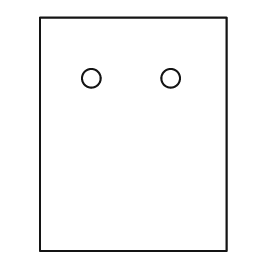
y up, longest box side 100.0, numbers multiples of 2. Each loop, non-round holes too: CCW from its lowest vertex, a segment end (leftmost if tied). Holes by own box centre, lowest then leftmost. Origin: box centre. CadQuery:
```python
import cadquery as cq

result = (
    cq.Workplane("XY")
    .moveTo(-40.0, -50.0)
    .lineTo(40.0, -50.0)
    .lineTo(40.0, 50.0)
    .lineTo(-40.0, 50.0)
    .close()
    .moveTo(-18.0, 24.0)
    .circle(4.0)
    .moveTo(16.0, 24.0)
    .circle(4.0)
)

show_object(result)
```